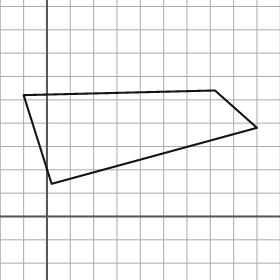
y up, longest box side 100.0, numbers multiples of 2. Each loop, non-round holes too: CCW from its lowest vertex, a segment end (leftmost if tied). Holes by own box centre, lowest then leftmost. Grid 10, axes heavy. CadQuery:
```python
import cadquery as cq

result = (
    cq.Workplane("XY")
    .moveTo(2.0, 14.0)
    .lineTo(90.0, 38.0)
    .lineTo(72.0, 54.0)
    .lineTo(-10.0, 52.0)
    .close()
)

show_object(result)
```